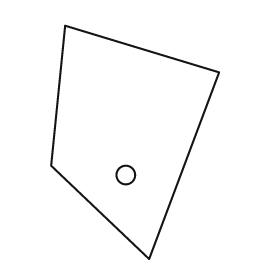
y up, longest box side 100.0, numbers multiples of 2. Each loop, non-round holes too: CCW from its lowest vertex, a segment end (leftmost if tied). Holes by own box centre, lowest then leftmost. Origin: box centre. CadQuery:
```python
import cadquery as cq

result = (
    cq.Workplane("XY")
    .moveTo(6.0, -50.0)
    .lineTo(36.0, 30.0)
    .lineTo(-30.0, 50.0)
    .lineTo(-36.0, -10.0)
    .close()
    .moveTo(-4.0, -14.0)
    .circle(4.0)
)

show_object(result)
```